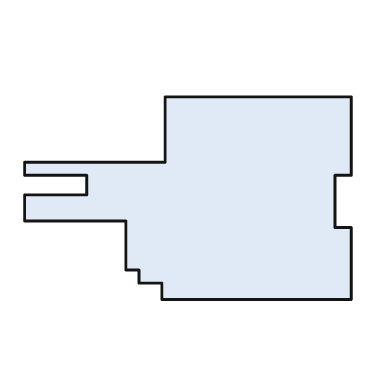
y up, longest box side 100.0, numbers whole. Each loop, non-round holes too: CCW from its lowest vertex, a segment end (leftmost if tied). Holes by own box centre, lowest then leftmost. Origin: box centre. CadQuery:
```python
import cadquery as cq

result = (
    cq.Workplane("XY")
    .moveTo(-8.0, -31.0)
    .lineTo(50.0, -31.0)
    .lineTo(50.0, -9.0)
    .lineTo(45.0, -9.0)
    .lineTo(45.0, 7.0)
    .lineTo(50.0, 7.0)
    .lineTo(50.0, 31.0)
    .lineTo(-7.0, 31.0)
    .lineTo(-7.0, 11.0)
    .lineTo(-50.0, 11.0)
    .lineTo(-50.0, 7.0)
    .lineTo(-31.0, 7.0)
    .lineTo(-31.0, 1.0)
    .lineTo(-50.0, 1.0)
    .lineTo(-50.0, -7.0)
    .lineTo(-19.0, -7.0)
    .lineTo(-19.0, -22.0)
    .lineTo(-15.0, -22.0)
    .lineTo(-15.0, -26.0)
    .lineTo(-8.0, -26.0)
    .close()
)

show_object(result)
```